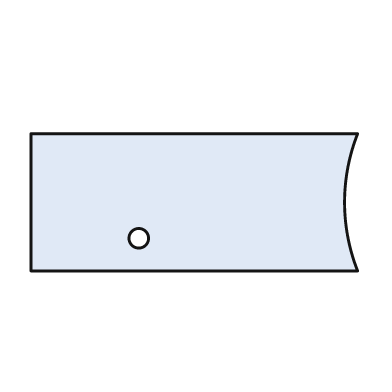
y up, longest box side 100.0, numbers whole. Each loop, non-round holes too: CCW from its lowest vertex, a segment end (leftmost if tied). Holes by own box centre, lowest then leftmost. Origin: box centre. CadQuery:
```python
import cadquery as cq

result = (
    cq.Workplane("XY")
    .moveTo(-50.0, -21.0)
    .lineTo(50.0, -21.0)
    .threePointArc((46.0, 0.0), (50.0, 21.0))
    .lineTo(-50.0, 21.0)
    .close()
    .moveTo(-17.0, -11.0)
    .circle(3.0)
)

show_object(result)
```